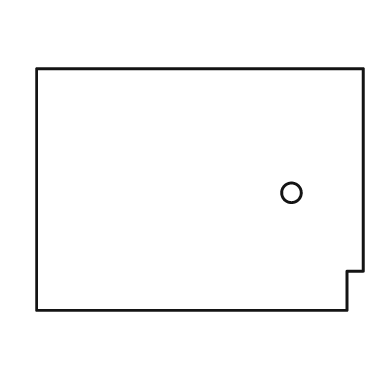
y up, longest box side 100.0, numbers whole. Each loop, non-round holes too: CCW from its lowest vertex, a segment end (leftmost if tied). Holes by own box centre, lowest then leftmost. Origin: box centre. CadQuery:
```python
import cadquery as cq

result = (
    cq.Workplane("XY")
    .moveTo(-50.0, -37.0)
    .lineTo(45.0, -37.0)
    .lineTo(45.0, -25.0)
    .lineTo(50.0, -25.0)
    .lineTo(50.0, 37.0)
    .lineTo(-50.0, 37.0)
    .close()
    .moveTo(28.0, -1.0)
    .circle(3.0)
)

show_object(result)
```